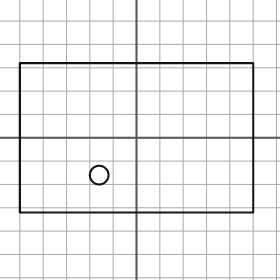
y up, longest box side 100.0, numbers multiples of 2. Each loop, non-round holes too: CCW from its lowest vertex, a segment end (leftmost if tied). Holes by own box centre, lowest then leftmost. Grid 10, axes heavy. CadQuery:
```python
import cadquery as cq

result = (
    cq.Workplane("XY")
    .moveTo(-50.0, -32.0)
    .lineTo(50.0, -32.0)
    .lineTo(50.0, 32.0)
    .lineTo(-50.0, 32.0)
    .close()
    .moveTo(-16.0, -16.0)
    .circle(4.0)
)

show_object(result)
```